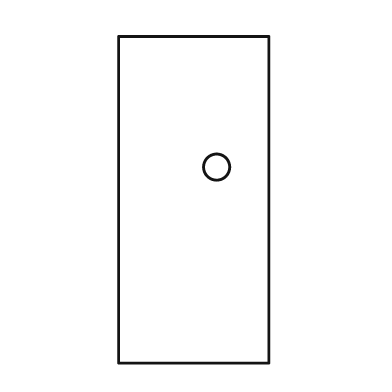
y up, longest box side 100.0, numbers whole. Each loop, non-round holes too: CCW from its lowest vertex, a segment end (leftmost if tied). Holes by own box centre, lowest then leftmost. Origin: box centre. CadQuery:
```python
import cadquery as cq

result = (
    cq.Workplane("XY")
    .moveTo(-23.0, -50.0)
    .lineTo(23.0, -50.0)
    .lineTo(23.0, 50.0)
    .lineTo(-23.0, 50.0)
    .close()
    .moveTo(7.0, 10.0)
    .circle(4.0)
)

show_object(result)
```